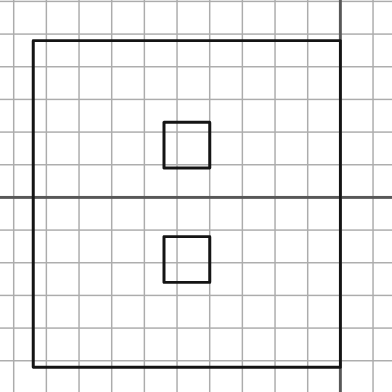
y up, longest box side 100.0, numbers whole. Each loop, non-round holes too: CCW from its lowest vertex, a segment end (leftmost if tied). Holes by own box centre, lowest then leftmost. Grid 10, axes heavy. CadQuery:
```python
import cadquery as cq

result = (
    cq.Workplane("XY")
    .moveTo(-94.0, -52.0)
    .lineTo(0.0, -52.0)
    .lineTo(0.0, 48.0)
    .lineTo(-94.0, 48.0)
    .close()
    .moveTo(-54.0, -26.0)
    .lineTo(-40.0, -26.0)
    .lineTo(-40.0, -12.0)
    .lineTo(-54.0, -12.0)
    .close()
    .moveTo(-54.0, 9.0)
    .lineTo(-40.0, 9.0)
    .lineTo(-40.0, 23.0)
    .lineTo(-54.0, 23.0)
    .close()
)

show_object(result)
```